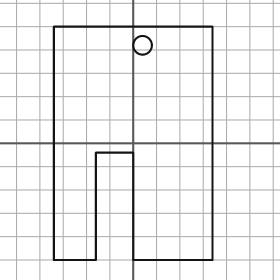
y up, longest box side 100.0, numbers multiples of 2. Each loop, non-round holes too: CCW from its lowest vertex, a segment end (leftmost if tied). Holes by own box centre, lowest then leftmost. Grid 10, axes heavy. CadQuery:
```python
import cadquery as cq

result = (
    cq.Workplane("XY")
    .moveTo(-34.0, -50.0)
    .lineTo(-16.0, -50.0)
    .lineTo(-16.0, -4.0)
    .lineTo(0.0, -4.0)
    .lineTo(0.0, -50.0)
    .lineTo(34.0, -50.0)
    .lineTo(34.0, 50.0)
    .lineTo(-34.0, 50.0)
    .close()
    .moveTo(4.0, 42.0)
    .circle(4.0)
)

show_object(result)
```